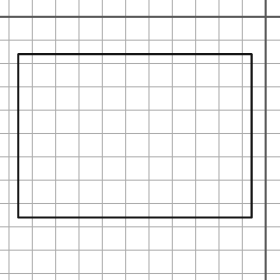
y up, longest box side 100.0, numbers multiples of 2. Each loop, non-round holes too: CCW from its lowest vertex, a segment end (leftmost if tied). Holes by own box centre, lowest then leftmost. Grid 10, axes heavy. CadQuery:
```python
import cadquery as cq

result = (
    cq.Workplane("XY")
    .moveTo(-106.0, -86.0)
    .lineTo(-6.0, -86.0)
    .lineTo(-6.0, -16.0)
    .lineTo(-106.0, -16.0)
    .close()
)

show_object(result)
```